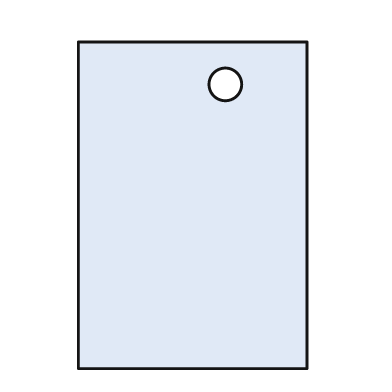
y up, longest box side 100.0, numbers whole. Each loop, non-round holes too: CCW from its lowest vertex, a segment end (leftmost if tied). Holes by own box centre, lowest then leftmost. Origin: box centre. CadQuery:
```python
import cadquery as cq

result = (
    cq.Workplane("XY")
    .moveTo(-35.0, -50.0)
    .lineTo(35.0, -50.0)
    .lineTo(35.0, 50.0)
    .lineTo(-35.0, 50.0)
    .close()
    .moveTo(10.0, 37.0)
    .circle(5.0)
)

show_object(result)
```